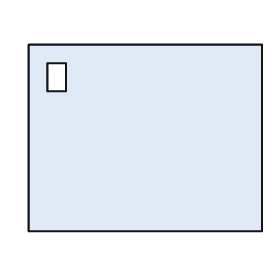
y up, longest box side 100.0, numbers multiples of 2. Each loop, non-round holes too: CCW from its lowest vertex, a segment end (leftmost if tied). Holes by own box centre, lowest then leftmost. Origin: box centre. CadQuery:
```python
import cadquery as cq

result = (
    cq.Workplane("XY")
    .moveTo(-50.0, -40.0)
    .lineTo(50.0, -40.0)
    .lineTo(50.0, 40.0)
    .lineTo(-50.0, 40.0)
    .close()
    .moveTo(-42.0, 20.0)
    .lineTo(-34.0, 20.0)
    .lineTo(-34.0, 32.0)
    .lineTo(-42.0, 32.0)
    .close()
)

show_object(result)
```